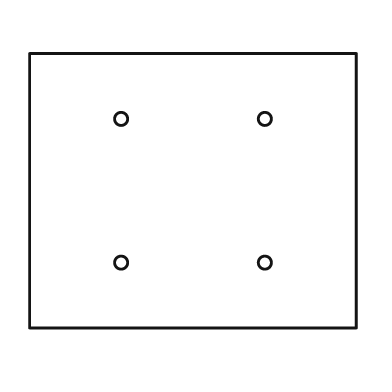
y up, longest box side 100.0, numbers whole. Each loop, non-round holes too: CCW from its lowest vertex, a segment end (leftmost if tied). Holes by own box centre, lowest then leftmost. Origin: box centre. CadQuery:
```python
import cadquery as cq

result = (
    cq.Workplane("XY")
    .moveTo(-50.0, -42.0)
    .lineTo(50.0, -42.0)
    .lineTo(50.0, 42.0)
    .lineTo(-50.0, 42.0)
    .close()
    .moveTo(-22.0, -22.0)
    .circle(2.0)
    .moveTo(22.0, -22.0)
    .circle(2.0)
    .moveTo(-22.0, 22.0)
    .circle(2.0)
    .moveTo(22.0, 22.0)
    .circle(2.0)
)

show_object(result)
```